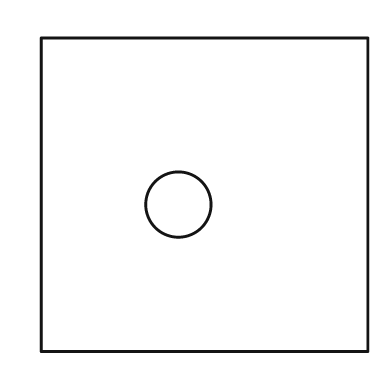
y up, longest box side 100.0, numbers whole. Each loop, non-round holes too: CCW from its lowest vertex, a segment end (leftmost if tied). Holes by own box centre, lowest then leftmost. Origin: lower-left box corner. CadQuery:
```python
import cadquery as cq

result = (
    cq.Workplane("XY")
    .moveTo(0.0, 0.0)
    .lineTo(100.0, 0.0)
    .lineTo(100.0, 96.0)
    .lineTo(0.0, 96.0)
    .close()
    .moveTo(42.0, 45.0)
    .circle(10.0)
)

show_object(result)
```